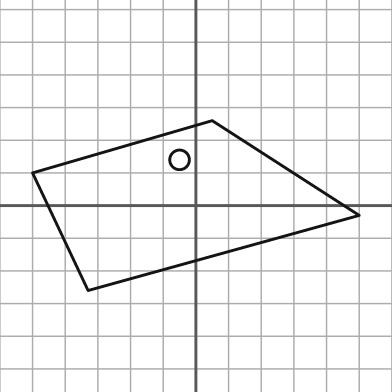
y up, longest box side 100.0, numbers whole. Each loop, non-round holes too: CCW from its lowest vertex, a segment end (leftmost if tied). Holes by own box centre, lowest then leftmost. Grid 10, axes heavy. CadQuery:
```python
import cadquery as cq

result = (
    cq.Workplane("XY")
    .moveTo(-33.0, -26.0)
    .lineTo(50.0, -3.0)
    .lineTo(5.0, 26.0)
    .lineTo(-50.0, 10.0)
    .close()
    .moveTo(-5.0, 14.0)
    .circle(3.0)
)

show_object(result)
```